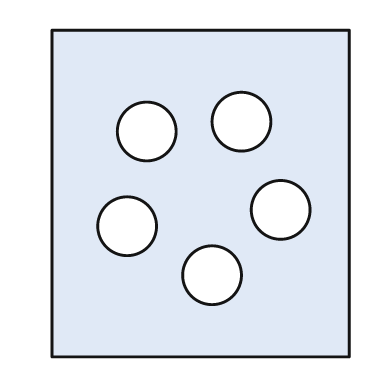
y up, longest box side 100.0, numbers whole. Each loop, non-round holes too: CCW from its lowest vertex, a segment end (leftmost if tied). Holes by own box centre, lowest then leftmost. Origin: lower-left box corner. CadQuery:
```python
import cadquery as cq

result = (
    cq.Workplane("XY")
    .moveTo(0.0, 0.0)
    .lineTo(91.0, 0.0)
    .lineTo(91.0, 100.0)
    .lineTo(0.0, 100.0)
    .close()
    .moveTo(49.0, 25.0)
    .circle(9.0)
    .moveTo(23.0, 40.0)
    .circle(9.0)
    .moveTo(70.0, 45.0)
    .circle(9.0)
    .moveTo(29.0, 69.0)
    .circle(9.0)
    .moveTo(58.0, 72.0)
    .circle(9.0)
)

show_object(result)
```